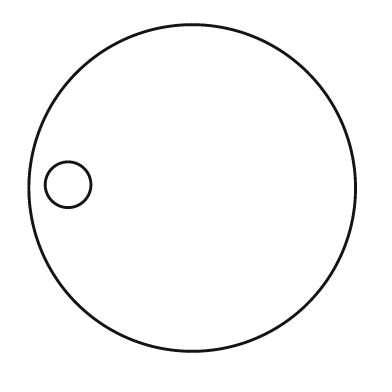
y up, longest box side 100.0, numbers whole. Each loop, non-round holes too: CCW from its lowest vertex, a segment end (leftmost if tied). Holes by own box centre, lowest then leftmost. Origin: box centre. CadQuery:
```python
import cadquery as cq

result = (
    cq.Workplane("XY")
    .moveTo(0.0, 0.0)
    .circle(50.0)
    .moveTo(-38.0, 1.0)
    .circle(7.0)
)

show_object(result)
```